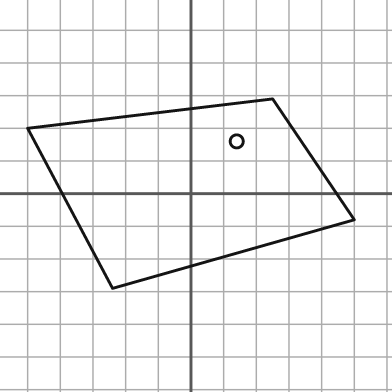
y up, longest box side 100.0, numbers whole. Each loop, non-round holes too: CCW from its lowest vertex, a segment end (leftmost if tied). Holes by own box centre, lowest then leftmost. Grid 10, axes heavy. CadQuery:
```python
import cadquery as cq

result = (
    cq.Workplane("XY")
    .moveTo(-24.0, -29.0)
    .lineTo(50.0, -8.0)
    .lineTo(25.0, 29.0)
    .lineTo(-50.0, 20.0)
    .close()
    .moveTo(14.0, 16.0)
    .circle(2.0)
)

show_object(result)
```